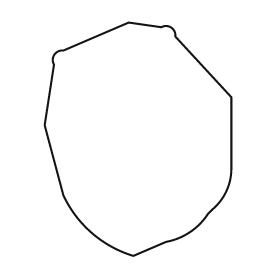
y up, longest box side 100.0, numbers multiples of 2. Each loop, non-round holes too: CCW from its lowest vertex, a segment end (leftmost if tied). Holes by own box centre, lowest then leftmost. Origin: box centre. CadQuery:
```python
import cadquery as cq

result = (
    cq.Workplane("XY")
    .moveTo(-2.0, -50.0)
    .lineTo(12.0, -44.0)
    .threePointArc((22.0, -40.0), (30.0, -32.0))
    .lineTo(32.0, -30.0)
    .threePointArc((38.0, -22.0), (40.0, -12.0))
    .lineTo(40.0, 18.0)
    .lineTo(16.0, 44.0)
    .threePointArc((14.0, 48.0), (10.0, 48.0))
    .lineTo(-4.0, 50.0)
    .lineTo(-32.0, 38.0)
    .threePointArc((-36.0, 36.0), (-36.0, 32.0))
    .lineTo(-40.0, 6.0)
    .lineTo(-32.0, -24.0)
    .threePointArc((-20.0, -40.0), (-2.0, -50.0))
    .close()
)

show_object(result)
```